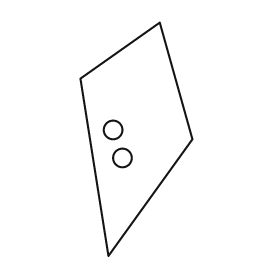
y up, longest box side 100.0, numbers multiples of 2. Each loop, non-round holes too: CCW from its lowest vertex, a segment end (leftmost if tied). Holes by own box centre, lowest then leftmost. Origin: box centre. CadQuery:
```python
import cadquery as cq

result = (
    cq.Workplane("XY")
    .moveTo(-12.0, -50.0)
    .lineTo(24.0, 0.0)
    .lineTo(10.0, 50.0)
    .lineTo(-24.0, 26.0)
    .close()
    .moveTo(-6.0, -8.0)
    .circle(4.0)
    .moveTo(-10.0, 4.0)
    .circle(4.0)
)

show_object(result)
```